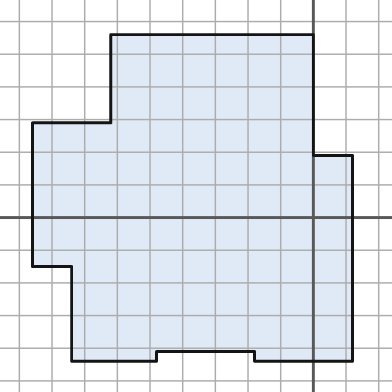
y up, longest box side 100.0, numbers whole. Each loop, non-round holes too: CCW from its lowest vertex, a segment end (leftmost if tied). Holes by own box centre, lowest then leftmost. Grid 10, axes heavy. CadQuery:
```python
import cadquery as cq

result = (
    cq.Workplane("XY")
    .moveTo(-74.0, -44.0)
    .lineTo(-48.0, -44.0)
    .lineTo(-48.0, -41.0)
    .lineTo(-18.0, -41.0)
    .lineTo(-18.0, -44.0)
    .lineTo(12.0, -44.0)
    .lineTo(12.0, 19.0)
    .lineTo(0.0, 19.0)
    .lineTo(0.0, 56.0)
    .lineTo(-62.0, 56.0)
    .lineTo(-62.0, 29.0)
    .lineTo(-86.0, 29.0)
    .lineTo(-86.0, -15.0)
    .lineTo(-74.0, -15.0)
    .close()
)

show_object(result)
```